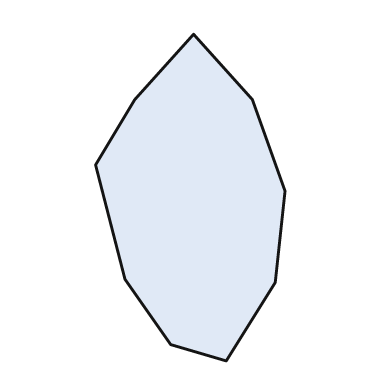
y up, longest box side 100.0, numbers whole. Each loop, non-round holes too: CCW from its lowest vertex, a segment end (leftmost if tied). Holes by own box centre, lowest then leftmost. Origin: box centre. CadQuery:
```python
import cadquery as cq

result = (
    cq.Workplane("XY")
    .moveTo(11.0, -50.0)
    .lineTo(26.0, -26.0)
    .lineTo(29.0, 2.0)
    .lineTo(19.0, 30.0)
    .lineTo(1.0, 50.0)
    .lineTo(-17.0, 30.0)
    .lineTo(-29.0, 10.0)
    .lineTo(-20.0, -25.0)
    .lineTo(-6.0, -45.0)
    .close()
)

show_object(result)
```